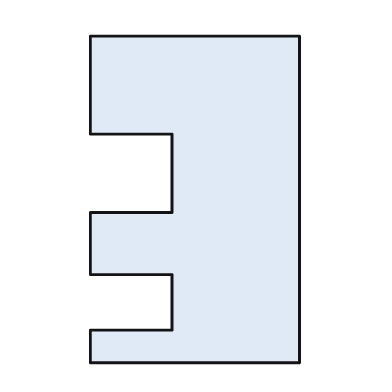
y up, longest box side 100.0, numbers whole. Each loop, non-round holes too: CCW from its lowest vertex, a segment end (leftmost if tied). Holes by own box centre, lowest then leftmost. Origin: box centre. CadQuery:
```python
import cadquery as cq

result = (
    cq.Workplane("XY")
    .moveTo(-32.0, -50.0)
    .lineTo(32.0, -50.0)
    .lineTo(32.0, 50.0)
    .lineTo(-32.0, 50.0)
    .lineTo(-32.0, 20.0)
    .lineTo(-7.0, 20.0)
    .lineTo(-7.0, -4.0)
    .lineTo(-32.0, -4.0)
    .lineTo(-32.0, -23.0)
    .lineTo(-7.0, -23.0)
    .lineTo(-7.0, -40.0)
    .lineTo(-32.0, -40.0)
    .close()
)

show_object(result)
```